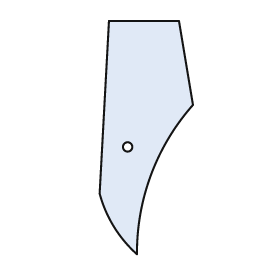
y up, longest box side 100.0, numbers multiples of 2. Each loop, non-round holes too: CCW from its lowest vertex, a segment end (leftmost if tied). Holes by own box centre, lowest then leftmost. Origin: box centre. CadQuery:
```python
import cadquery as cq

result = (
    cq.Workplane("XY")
    .moveTo(-4.0, -50.0)
    .threePointArc((2.0, -16.0), (20.0, 14.0))
    .lineTo(14.0, 50.0)
    .lineTo(-16.0, 50.0)
    .lineTo(-20.0, -24.0)
    .threePointArc((-14.0, -38.0), (-4.0, -50.0))
    .close()
    .moveTo(-8.0, -4.0)
    .circle(2.0)
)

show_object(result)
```